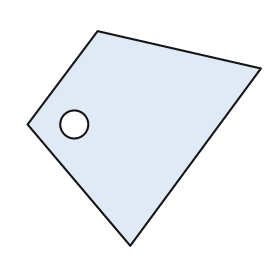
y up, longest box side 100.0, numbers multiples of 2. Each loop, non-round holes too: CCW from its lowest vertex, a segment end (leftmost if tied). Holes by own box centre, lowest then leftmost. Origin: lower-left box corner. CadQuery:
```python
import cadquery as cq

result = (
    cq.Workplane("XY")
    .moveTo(44.0, 0.0)
    .lineTo(100.0, 76.0)
    .lineTo(30.0, 92.0)
    .lineTo(0.0, 52.0)
    .close()
    .moveTo(20.0, 52.0)
    .circle(6.0)
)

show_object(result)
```